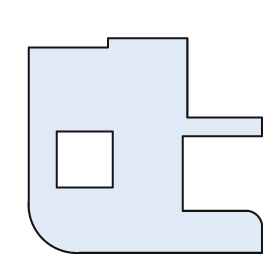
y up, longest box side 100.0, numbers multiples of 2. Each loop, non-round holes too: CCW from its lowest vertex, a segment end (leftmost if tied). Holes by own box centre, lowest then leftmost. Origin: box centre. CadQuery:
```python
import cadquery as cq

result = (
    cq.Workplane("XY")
    .moveTo(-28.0, -46.0)
    .lineTo(50.0, -46.0)
    .lineTo(50.0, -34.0)
    .threePointArc((48.0, -30.0), (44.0, -28.0))
    .lineTo(16.0, -28.0)
    .lineTo(16.0, 4.0)
    .lineTo(50.0, 4.0)
    .lineTo(50.0, 12.0)
    .lineTo(18.0, 12.0)
    .lineTo(18.0, 46.0)
    .lineTo(-16.0, 46.0)
    .lineTo(-16.0, 42.0)
    .lineTo(-50.0, 42.0)
    .lineTo(-50.0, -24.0)
    .threePointArc((-44.0, -40.0), (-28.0, -46.0))
    .close()
    .moveTo(-38.0, -18.0)
    .lineTo(-14.0, -18.0)
    .lineTo(-14.0, 6.0)
    .lineTo(-38.0, 6.0)
    .close()
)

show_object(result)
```